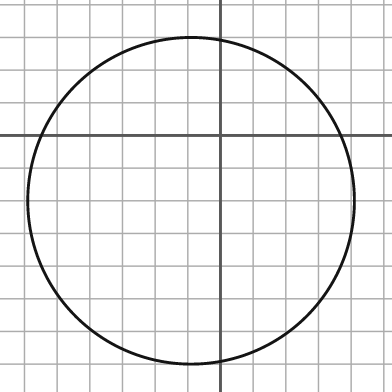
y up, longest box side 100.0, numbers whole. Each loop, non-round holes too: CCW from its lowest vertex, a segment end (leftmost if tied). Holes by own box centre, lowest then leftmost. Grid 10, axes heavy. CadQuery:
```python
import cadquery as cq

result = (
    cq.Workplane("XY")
    .moveTo(-9.0, -20.0)
    .circle(50.0)
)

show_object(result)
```